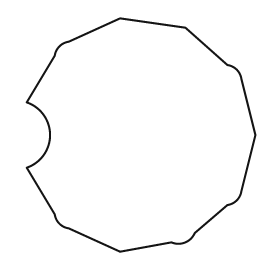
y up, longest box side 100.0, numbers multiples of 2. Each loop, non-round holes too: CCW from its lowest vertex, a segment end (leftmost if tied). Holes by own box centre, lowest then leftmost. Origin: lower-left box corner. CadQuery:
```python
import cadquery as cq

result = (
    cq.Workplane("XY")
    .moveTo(40.0, 0.0)
    .lineTo(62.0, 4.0)
    .threePointArc((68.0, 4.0), (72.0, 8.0))
    .lineTo(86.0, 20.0)
    .threePointArc((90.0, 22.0), (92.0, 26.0))
    .lineTo(98.0, 50.0)
    .lineTo(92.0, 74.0)
    .threePointArc((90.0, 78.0), (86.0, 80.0))
    .lineTo(68.0, 96.0)
    .lineTo(40.0, 100.0)
    .lineTo(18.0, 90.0)
    .threePointArc((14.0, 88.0), (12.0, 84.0))
    .lineTo(0.0, 64.0)
    .threePointArc((10.0, 50.0), (0.0, 36.0))
    .lineTo(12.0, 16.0)
    .threePointArc((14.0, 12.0), (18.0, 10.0))
    .close()
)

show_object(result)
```